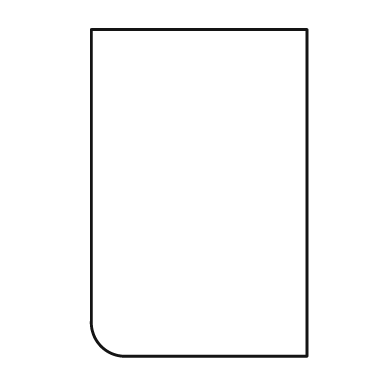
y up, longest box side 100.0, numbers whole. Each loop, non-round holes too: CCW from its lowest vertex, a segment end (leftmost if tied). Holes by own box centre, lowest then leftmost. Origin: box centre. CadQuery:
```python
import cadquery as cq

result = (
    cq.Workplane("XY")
    .moveTo(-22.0, -50.0)
    .lineTo(33.0, -50.0)
    .lineTo(33.0, 50.0)
    .lineTo(-33.0, 50.0)
    .lineTo(-33.0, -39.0)
    .threePointArc((-30.0, -47.0), (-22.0, -50.0))
    .close()
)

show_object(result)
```